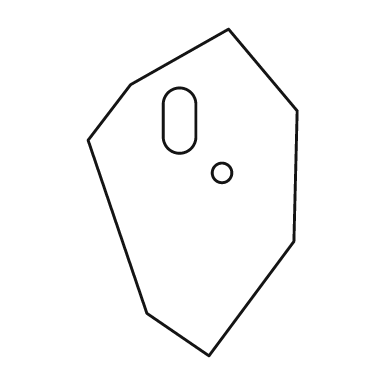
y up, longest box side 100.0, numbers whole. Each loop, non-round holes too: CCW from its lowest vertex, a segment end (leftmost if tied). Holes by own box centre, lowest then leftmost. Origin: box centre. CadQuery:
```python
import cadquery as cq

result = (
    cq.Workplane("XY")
    .moveTo(5.0, -50.0)
    .lineTo(31.0, -15.0)
    .lineTo(32.0, 25.0)
    .lineTo(11.0, 50.0)
    .lineTo(-19.0, 33.0)
    .lineTo(-32.0, 16.0)
    .lineTo(-14.0, -37.0)
    .close()
    .moveTo(9.0, 6.0)
    .circle(3.0)
    .moveTo(-9.0, 17.0)
    .threePointArc((-4.0, 12.0), (1.0, 17.0))
    .lineTo(1.0, 27.0)
    .threePointArc((-4.0, 32.0), (-9.0, 27.0))
    .close()
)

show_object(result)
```